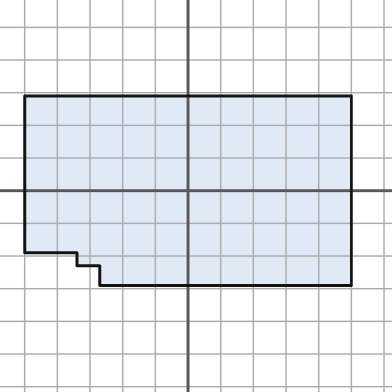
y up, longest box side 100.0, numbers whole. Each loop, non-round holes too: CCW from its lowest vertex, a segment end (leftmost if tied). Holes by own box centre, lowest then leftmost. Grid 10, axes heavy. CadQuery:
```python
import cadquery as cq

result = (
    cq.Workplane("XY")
    .moveTo(-27.0, -29.0)
    .lineTo(50.0, -29.0)
    .lineTo(50.0, 29.0)
    .lineTo(-50.0, 29.0)
    .lineTo(-50.0, -19.0)
    .lineTo(-34.0, -19.0)
    .lineTo(-34.0, -23.0)
    .lineTo(-27.0, -23.0)
    .close()
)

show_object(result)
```